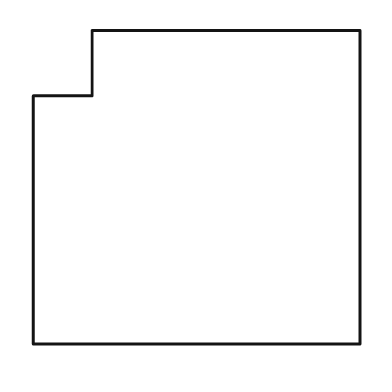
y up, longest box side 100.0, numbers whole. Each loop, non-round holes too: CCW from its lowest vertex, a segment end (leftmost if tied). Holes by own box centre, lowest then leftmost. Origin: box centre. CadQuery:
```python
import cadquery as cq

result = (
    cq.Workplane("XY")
    .moveTo(-50.0, -48.0)
    .lineTo(50.0, -48.0)
    .lineTo(50.0, 48.0)
    .lineTo(-32.0, 48.0)
    .lineTo(-32.0, 28.0)
    .lineTo(-50.0, 28.0)
    .close()
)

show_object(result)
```